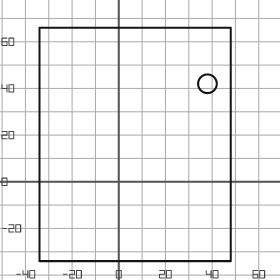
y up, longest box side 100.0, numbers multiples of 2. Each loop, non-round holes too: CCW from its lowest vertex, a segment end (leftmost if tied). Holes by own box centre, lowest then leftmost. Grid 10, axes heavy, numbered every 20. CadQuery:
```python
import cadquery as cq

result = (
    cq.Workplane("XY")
    .moveTo(-34.0, -34.0)
    .lineTo(48.0, -34.0)
    .lineTo(48.0, 66.0)
    .lineTo(-34.0, 66.0)
    .close()
    .moveTo(38.0, 42.0)
    .circle(4.0)
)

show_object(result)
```